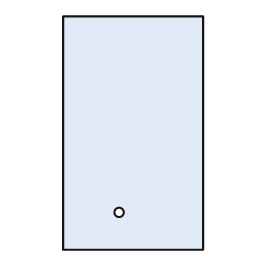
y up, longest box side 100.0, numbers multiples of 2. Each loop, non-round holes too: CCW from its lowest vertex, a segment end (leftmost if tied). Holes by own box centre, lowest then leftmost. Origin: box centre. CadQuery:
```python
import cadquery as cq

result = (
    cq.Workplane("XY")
    .moveTo(-30.0, -50.0)
    .lineTo(30.0, -50.0)
    .lineTo(30.0, 50.0)
    .lineTo(-30.0, 50.0)
    .close()
    .moveTo(-6.0, -34.0)
    .circle(2.0)
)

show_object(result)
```